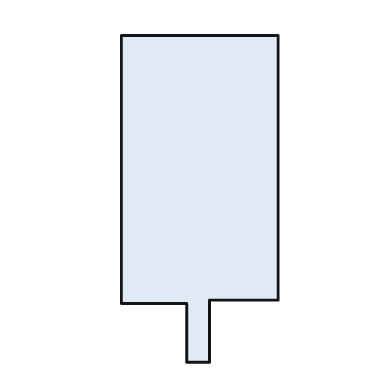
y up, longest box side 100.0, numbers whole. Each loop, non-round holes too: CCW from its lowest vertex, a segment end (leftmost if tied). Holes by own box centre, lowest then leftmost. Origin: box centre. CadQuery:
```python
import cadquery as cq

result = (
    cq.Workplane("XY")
    .moveTo(-4.0, -50.0)
    .lineTo(3.0, -50.0)
    .lineTo(3.0, -31.0)
    .lineTo(24.0, -31.0)
    .lineTo(24.0, 50.0)
    .lineTo(-24.0, 50.0)
    .lineTo(-24.0, -32.0)
    .lineTo(-4.0, -32.0)
    .close()
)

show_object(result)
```